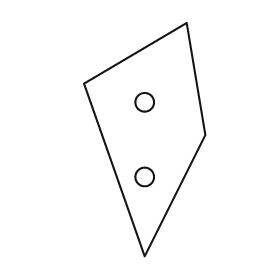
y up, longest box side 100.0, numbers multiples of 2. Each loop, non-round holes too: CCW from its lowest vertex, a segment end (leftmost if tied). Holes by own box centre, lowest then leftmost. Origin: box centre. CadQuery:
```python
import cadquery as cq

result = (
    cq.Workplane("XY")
    .moveTo(0.0, -50.0)
    .lineTo(26.0, 2.0)
    .lineTo(18.0, 50.0)
    .lineTo(-26.0, 24.0)
    .close()
    .moveTo(0.0, -16.0)
    .circle(4.0)
    .moveTo(0.0, 16.0)
    .circle(4.0)
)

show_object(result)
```